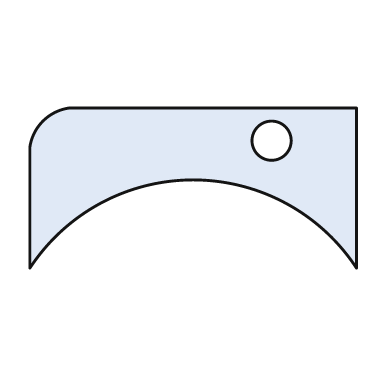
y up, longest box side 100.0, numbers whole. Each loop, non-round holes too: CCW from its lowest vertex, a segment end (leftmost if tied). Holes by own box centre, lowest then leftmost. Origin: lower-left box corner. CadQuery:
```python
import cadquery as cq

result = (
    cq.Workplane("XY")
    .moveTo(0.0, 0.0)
    .threePointArc((50.0, 27.0), (100.0, 0.0))
    .lineTo(100.0, 49.0)
    .lineTo(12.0, 49.0)
    .threePointArc((4.0, 45.0), (0.0, 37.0))
    .close()
    .moveTo(74.0, 39.0)
    .circle(6.0)
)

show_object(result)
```